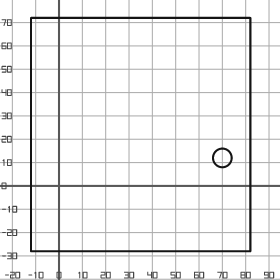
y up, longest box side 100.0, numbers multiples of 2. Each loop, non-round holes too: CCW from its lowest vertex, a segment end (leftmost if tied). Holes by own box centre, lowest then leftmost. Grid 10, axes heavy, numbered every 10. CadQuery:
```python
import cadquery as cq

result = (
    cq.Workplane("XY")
    .moveTo(-12.0, -28.0)
    .lineTo(82.0, -28.0)
    .lineTo(82.0, 72.0)
    .lineTo(-12.0, 72.0)
    .close()
    .moveTo(70.0, 12.0)
    .circle(4.0)
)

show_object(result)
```